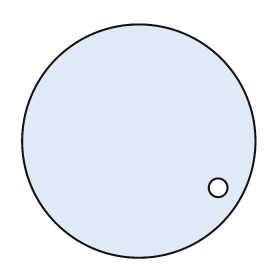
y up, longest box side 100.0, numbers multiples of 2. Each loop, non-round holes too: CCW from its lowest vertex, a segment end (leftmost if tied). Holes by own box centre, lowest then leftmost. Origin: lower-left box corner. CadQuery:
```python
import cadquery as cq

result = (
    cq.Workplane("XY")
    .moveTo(50.0, 50.0)
    .circle(50.0)
    .moveTo(84.0, 30.0)
    .circle(4.0)
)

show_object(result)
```